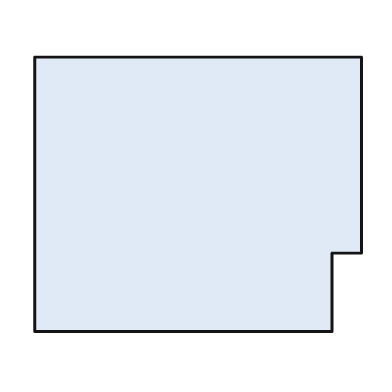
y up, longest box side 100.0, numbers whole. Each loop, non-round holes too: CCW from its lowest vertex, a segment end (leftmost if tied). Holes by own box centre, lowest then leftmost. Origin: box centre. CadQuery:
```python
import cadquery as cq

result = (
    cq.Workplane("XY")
    .moveTo(-50.0, -42.0)
    .lineTo(41.0, -42.0)
    .lineTo(41.0, -18.0)
    .lineTo(50.0, -18.0)
    .lineTo(50.0, 42.0)
    .lineTo(-50.0, 42.0)
    .close()
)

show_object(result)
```